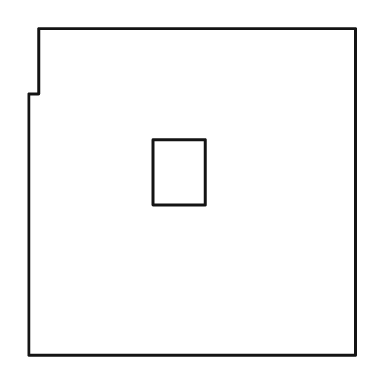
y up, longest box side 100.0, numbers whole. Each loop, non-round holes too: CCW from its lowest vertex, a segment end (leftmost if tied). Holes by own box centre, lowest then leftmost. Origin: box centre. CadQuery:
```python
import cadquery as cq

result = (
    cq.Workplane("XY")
    .moveTo(-50.0, -50.0)
    .lineTo(50.0, -50.0)
    .lineTo(50.0, 50.0)
    .lineTo(-47.0, 50.0)
    .lineTo(-47.0, 30.0)
    .lineTo(-50.0, 30.0)
    .close()
    .moveTo(-12.0, -4.0)
    .lineTo(4.0, -4.0)
    .lineTo(4.0, 16.0)
    .lineTo(-12.0, 16.0)
    .close()
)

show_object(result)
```